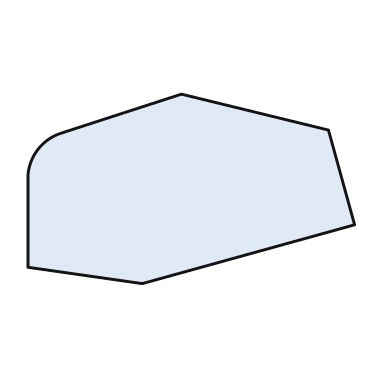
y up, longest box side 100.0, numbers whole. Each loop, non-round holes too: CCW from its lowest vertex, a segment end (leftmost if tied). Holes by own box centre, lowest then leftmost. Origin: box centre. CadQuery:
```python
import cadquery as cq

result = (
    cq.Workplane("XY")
    .moveTo(-15.0, -29.0)
    .lineTo(50.0, -11.0)
    .lineTo(42.0, 18.0)
    .lineTo(-3.0, 29.0)
    .lineTo(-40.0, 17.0)
    .threePointArc((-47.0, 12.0), (-50.0, 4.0))
    .lineTo(-50.0, -24.0)
    .close()
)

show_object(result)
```